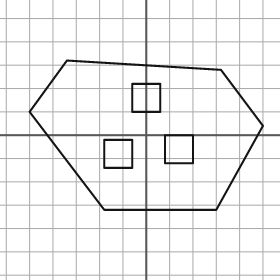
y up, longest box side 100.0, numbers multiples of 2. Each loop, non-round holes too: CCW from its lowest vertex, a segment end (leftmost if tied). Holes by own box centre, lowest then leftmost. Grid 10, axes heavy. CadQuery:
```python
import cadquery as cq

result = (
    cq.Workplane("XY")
    .moveTo(-18.0, -32.0)
    .lineTo(30.0, -32.0)
    .lineTo(50.0, 4.0)
    .lineTo(32.0, 28.0)
    .lineTo(-34.0, 32.0)
    .lineTo(-50.0, 10.0)
    .close()
    .moveTo(-18.0, -14.0)
    .lineTo(-6.0, -14.0)
    .lineTo(-6.0, -2.0)
    .lineTo(-18.0, -2.0)
    .close()
    .moveTo(8.0, -12.0)
    .lineTo(20.0, -12.0)
    .lineTo(20.0, 0.0)
    .lineTo(8.0, 0.0)
    .close()
    .moveTo(-6.0, 10.0)
    .lineTo(6.0, 10.0)
    .lineTo(6.0, 22.0)
    .lineTo(-6.0, 22.0)
    .close()
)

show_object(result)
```